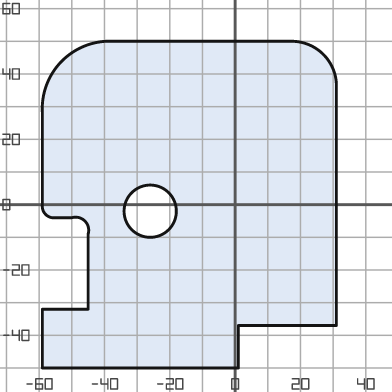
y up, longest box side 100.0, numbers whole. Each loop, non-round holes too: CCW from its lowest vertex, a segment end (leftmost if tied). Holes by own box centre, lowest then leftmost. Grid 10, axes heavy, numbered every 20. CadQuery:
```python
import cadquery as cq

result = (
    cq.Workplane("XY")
    .moveTo(-59.0, -50.0)
    .lineTo(1.0, -50.0)
    .lineTo(1.0, -37.0)
    .lineTo(31.0, -37.0)
    .lineTo(31.0, 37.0)
    .threePointArc((27.0, 46.0), (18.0, 50.0))
    .lineTo(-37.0, 50.0)
    .threePointArc((-53.0, 44.0), (-59.0, 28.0))
    .lineTo(-59.0, 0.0)
    .threePointArc((-58.0, -3.0), (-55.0, -4.0))
    .lineTo(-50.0, -4.0)
    .threePointArc((-46.0, -5.0), (-45.0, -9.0))
    .lineTo(-45.0, -32.0)
    .lineTo(-59.0, -32.0)
    .close()
    .moveTo(-26.0, -2.0)
    .circle(8.0)
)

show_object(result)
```